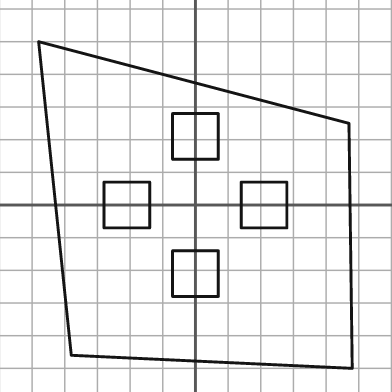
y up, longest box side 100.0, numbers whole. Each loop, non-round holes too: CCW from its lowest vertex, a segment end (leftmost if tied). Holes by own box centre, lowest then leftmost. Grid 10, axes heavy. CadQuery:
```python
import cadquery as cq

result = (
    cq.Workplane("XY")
    .moveTo(48.0, -50.0)
    .lineTo(47.0, 25.0)
    .lineTo(-48.0, 50.0)
    .lineTo(-38.0, -46.0)
    .close()
    .moveTo(-7.0, -28.0)
    .lineTo(7.0, -28.0)
    .lineTo(7.0, -14.0)
    .lineTo(-7.0, -14.0)
    .close()
    .moveTo(-28.0, -7.0)
    .lineTo(-14.0, -7.0)
    .lineTo(-14.0, 7.0)
    .lineTo(-28.0, 7.0)
    .close()
    .moveTo(14.0, -7.0)
    .lineTo(28.0, -7.0)
    .lineTo(28.0, 7.0)
    .lineTo(14.0, 7.0)
    .close()
    .moveTo(-7.0, 14.0)
    .lineTo(7.0, 14.0)
    .lineTo(7.0, 28.0)
    .lineTo(-7.0, 28.0)
    .close()
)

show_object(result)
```